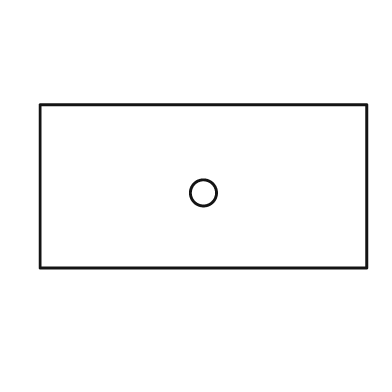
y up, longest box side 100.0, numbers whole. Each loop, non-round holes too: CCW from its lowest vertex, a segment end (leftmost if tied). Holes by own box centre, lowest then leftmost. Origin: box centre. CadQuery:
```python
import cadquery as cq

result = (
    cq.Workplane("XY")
    .moveTo(-50.0, -25.0)
    .lineTo(50.0, -25.0)
    .lineTo(50.0, 25.0)
    .lineTo(-50.0, 25.0)
    .close()
    .moveTo(0.0, -2.0)
    .circle(4.0)
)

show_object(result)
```